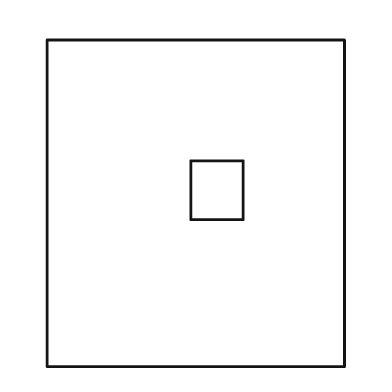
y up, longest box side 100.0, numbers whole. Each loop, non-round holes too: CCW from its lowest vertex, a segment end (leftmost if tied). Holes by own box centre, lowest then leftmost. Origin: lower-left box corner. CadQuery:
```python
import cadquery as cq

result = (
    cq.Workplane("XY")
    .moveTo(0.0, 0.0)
    .lineTo(91.0, 0.0)
    .lineTo(91.0, 100.0)
    .lineTo(0.0, 100.0)
    .close()
    .moveTo(44.0, 45.0)
    .lineTo(60.0, 45.0)
    .lineTo(60.0, 63.0)
    .lineTo(44.0, 63.0)
    .close()
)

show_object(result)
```